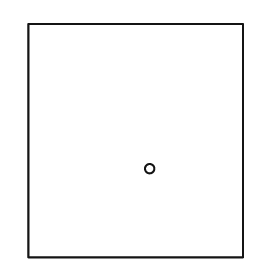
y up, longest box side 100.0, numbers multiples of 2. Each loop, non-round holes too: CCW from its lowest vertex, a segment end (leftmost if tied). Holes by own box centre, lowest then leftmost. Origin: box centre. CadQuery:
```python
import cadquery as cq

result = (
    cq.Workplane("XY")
    .moveTo(-46.0, -50.0)
    .lineTo(46.0, -50.0)
    .lineTo(46.0, 50.0)
    .lineTo(-46.0, 50.0)
    .close()
    .moveTo(6.0, -12.0)
    .circle(2.0)
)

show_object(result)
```